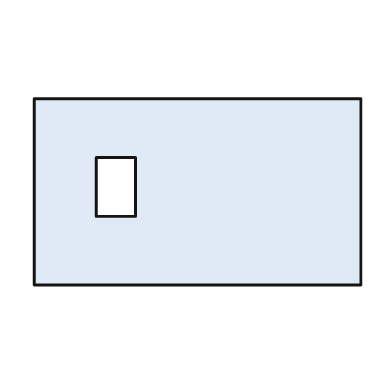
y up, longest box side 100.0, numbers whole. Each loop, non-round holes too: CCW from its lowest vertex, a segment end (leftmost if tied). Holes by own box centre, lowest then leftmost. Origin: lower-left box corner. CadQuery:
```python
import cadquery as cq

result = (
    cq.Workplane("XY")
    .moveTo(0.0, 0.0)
    .lineTo(100.0, 0.0)
    .lineTo(100.0, 57.0)
    .lineTo(0.0, 57.0)
    .close()
    .moveTo(19.0, 21.0)
    .lineTo(31.0, 21.0)
    .lineTo(31.0, 39.0)
    .lineTo(19.0, 39.0)
    .close()
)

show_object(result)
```